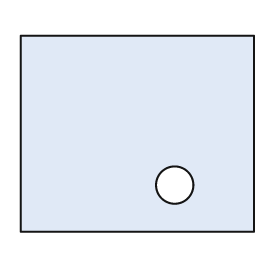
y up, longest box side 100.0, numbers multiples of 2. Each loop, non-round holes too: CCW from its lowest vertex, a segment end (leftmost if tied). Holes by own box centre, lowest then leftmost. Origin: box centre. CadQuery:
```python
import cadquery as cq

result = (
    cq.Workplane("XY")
    .moveTo(-50.0, -42.0)
    .lineTo(50.0, -42.0)
    .lineTo(50.0, 42.0)
    .lineTo(-50.0, 42.0)
    .close()
    .moveTo(16.0, -22.0)
    .circle(8.0)
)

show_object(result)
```